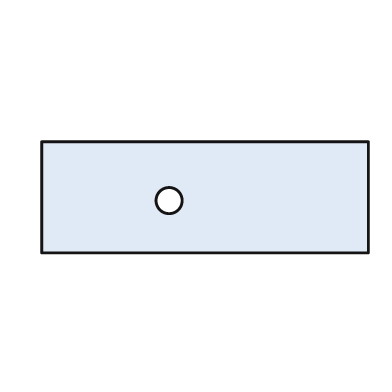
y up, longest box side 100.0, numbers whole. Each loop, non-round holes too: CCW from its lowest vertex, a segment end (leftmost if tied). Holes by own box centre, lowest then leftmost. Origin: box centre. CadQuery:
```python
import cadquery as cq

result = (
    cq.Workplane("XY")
    .moveTo(-50.0, -17.0)
    .lineTo(50.0, -17.0)
    .lineTo(50.0, 17.0)
    .lineTo(-50.0, 17.0)
    .close()
    .moveTo(-11.0, -1.0)
    .circle(4.0)
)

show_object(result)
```